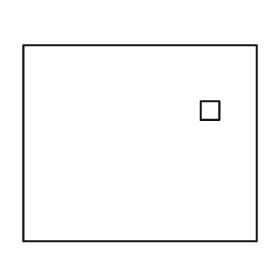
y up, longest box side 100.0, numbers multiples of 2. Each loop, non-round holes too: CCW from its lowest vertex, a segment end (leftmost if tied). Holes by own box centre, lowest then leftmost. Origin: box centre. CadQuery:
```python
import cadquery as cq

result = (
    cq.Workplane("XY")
    .moveTo(-50.0, -42.0)
    .lineTo(50.0, -42.0)
    .lineTo(50.0, 42.0)
    .lineTo(-50.0, 42.0)
    .close()
    .moveTo(26.0, 10.0)
    .lineTo(34.0, 10.0)
    .lineTo(34.0, 18.0)
    .lineTo(26.0, 18.0)
    .close()
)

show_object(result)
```